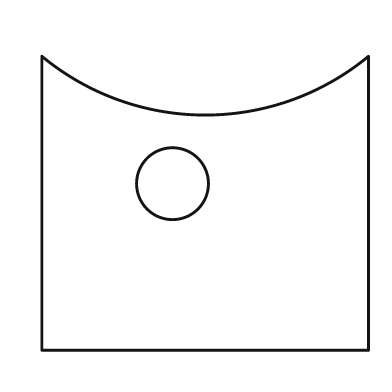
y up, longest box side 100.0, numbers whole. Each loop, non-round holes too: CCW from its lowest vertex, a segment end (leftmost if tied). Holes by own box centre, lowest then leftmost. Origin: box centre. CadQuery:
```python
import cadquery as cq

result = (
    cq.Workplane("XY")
    .moveTo(-50.0, -45.0)
    .lineTo(50.0, -45.0)
    .lineTo(50.0, 45.0)
    .threePointArc((0.0, 27.0), (-50.0, 45.0))
    .close()
    .moveTo(-10.0, 6.0)
    .circle(11.0)
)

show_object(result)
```